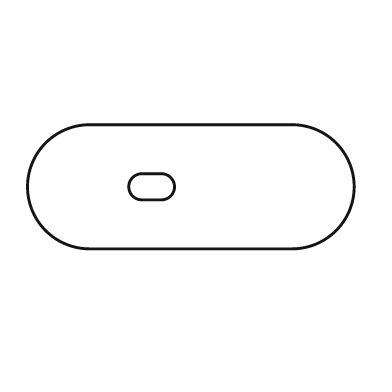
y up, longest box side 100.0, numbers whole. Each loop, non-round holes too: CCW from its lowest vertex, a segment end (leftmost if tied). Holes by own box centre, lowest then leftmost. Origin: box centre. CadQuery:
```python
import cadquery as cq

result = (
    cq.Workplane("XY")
    .moveTo(-31.0, -19.0)
    .lineTo(31.0, -19.0)
    .threePointArc((50.0, 0.0), (31.0, 19.0))
    .lineTo(-31.0, 19.0)
    .threePointArc((-50.0, 0.0), (-31.0, -19.0))
    .close()
    .moveTo(-15.0, -4.0)
    .lineTo(-9.0, -4.0)
    .threePointArc((-5.0, 0.0), (-9.0, 4.0))
    .lineTo(-15.0, 4.0)
    .threePointArc((-19.0, 0.0), (-15.0, -4.0))
    .close()
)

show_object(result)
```